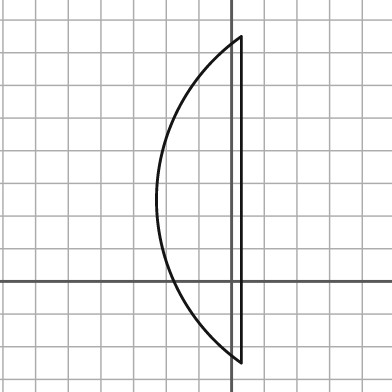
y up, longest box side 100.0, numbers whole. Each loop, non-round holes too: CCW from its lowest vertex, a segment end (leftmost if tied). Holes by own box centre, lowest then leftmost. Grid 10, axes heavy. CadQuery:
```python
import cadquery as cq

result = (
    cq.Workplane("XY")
    .moveTo(3.0, -25.0)
    .lineTo(3.0, 75.0)
    .threePointArc((-23.0, 25.0), (3.0, -25.0))
    .close()
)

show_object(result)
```